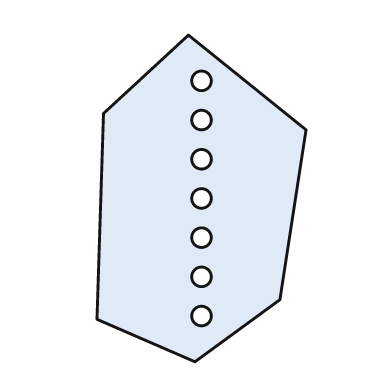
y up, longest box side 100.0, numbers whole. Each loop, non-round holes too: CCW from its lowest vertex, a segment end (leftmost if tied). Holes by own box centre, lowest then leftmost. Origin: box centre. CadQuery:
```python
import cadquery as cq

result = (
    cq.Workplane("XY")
    .moveTo(-2.0, -50.0)
    .lineTo(24.0, -31.0)
    .lineTo(32.0, 21.0)
    .lineTo(-4.0, 50.0)
    .lineTo(-30.0, 26.0)
    .lineTo(-32.0, -37.0)
    .close()
    .moveTo(0.0, -36.0)
    .circle(3.0)
    .moveTo(0.0, -24.0)
    .circle(3.0)
    .moveTo(0.0, -12.0)
    .circle(3.0)
    .moveTo(0.0, 0.0)
    .circle(3.0)
    .moveTo(0.0, 12.0)
    .circle(3.0)
    .moveTo(0.0, 24.0)
    .circle(3.0)
    .moveTo(0.0, 36.0)
    .circle(3.0)
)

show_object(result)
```